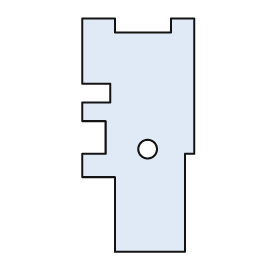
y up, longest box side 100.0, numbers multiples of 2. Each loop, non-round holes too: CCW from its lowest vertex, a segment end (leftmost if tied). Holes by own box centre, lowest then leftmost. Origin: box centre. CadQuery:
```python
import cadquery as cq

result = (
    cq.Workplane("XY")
    .moveTo(-10.0, -50.0)
    .lineTo(20.0, -50.0)
    .lineTo(20.0, -8.0)
    .lineTo(24.0, -8.0)
    .lineTo(24.0, 50.0)
    .lineTo(14.0, 50.0)
    .lineTo(14.0, 44.0)
    .lineTo(-10.0, 44.0)
    .lineTo(-10.0, 50.0)
    .lineTo(-24.0, 50.0)
    .lineTo(-24.0, 22.0)
    .lineTo(-12.0, 22.0)
    .lineTo(-12.0, 14.0)
    .lineTo(-24.0, 14.0)
    .lineTo(-24.0, 6.0)
    .lineTo(-14.0, 6.0)
    .lineTo(-14.0, -8.0)
    .lineTo(-24.0, -8.0)
    .lineTo(-24.0, -18.0)
    .lineTo(-10.0, -18.0)
    .close()
    .moveTo(4.0, -6.0)
    .circle(4.0)
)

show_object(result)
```